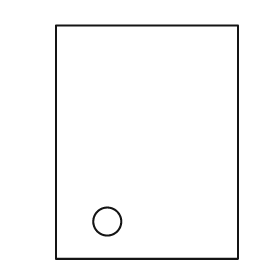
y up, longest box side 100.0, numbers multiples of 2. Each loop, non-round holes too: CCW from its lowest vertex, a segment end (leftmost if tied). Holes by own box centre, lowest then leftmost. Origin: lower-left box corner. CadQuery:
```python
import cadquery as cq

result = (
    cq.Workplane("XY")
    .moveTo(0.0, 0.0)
    .lineTo(78.0, 0.0)
    .lineTo(78.0, 100.0)
    .lineTo(0.0, 100.0)
    .close()
    .moveTo(22.0, 16.0)
    .circle(6.0)
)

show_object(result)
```